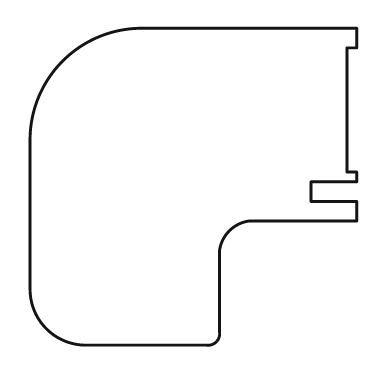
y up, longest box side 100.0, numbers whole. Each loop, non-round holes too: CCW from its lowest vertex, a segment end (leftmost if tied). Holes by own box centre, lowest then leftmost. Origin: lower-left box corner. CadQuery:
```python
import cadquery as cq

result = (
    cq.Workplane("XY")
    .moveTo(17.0, 0.0)
    .lineTo(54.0, 0.0)
    .threePointArc((57.0, 1.0), (58.0, 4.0))
    .lineTo(58.0, 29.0)
    .threePointArc((61.0, 35.0), (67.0, 38.0))
    .lineTo(100.0, 38.0)
    .lineTo(100.0, 44.0)
    .lineTo(86.0, 44.0)
    .lineTo(86.0, 50.0)
    .lineTo(100.0, 50.0)
    .lineTo(100.0, 53.0)
    .lineTo(97.0, 53.0)
    .lineTo(97.0, 91.0)
    .lineTo(100.0, 91.0)
    .lineTo(100.0, 97.0)
    .lineTo(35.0, 97.0)
    .threePointArc((10.0, 87.0), (0.0, 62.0))
    .lineTo(0.0, 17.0)
    .threePointArc((5.0, 5.0), (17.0, 0.0))
    .close()
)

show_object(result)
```